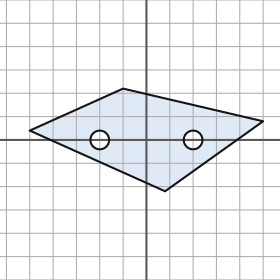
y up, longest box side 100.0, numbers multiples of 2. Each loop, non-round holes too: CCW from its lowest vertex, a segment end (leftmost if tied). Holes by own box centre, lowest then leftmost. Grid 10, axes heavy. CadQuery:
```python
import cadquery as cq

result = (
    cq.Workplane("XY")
    .moveTo(8.0, -22.0)
    .lineTo(50.0, 8.0)
    .lineTo(-10.0, 22.0)
    .lineTo(-50.0, 4.0)
    .close()
    .moveTo(-20.0, 0.0)
    .circle(4.0)
    .moveTo(20.0, 0.0)
    .circle(4.0)
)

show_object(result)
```